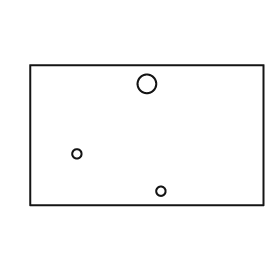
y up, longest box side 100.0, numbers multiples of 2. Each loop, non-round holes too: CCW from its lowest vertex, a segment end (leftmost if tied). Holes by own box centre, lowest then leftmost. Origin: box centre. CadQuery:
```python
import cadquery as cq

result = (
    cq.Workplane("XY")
    .moveTo(-50.0, -30.0)
    .lineTo(50.0, -30.0)
    .lineTo(50.0, 30.0)
    .lineTo(-50.0, 30.0)
    .close()
    .moveTo(6.0, -24.0)
    .circle(2.0)
    .moveTo(-30.0, -8.0)
    .circle(2.0)
    .moveTo(0.0, 22.0)
    .circle(4.0)
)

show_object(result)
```